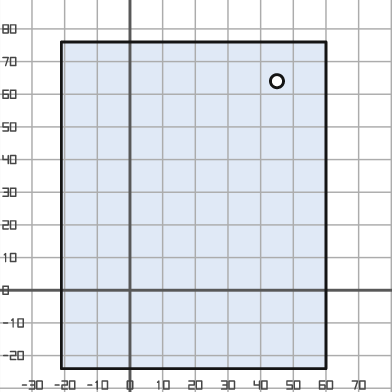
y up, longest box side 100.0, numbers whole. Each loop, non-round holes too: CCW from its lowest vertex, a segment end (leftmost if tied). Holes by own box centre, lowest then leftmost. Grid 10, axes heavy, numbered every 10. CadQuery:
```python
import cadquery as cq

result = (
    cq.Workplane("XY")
    .moveTo(-21.0, -24.0)
    .lineTo(60.0, -24.0)
    .lineTo(60.0, 76.0)
    .lineTo(-21.0, 76.0)
    .close()
    .moveTo(45.0, 64.0)
    .circle(2.0)
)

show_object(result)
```